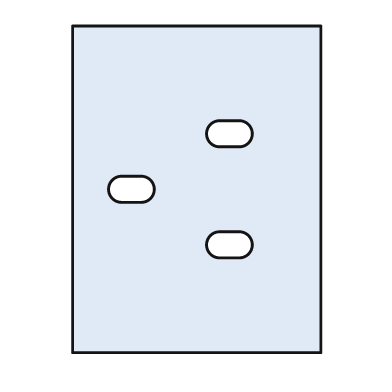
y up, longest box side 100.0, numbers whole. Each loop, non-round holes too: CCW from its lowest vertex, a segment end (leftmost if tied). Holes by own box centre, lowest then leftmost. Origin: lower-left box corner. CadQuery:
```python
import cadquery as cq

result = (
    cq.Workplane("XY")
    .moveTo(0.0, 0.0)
    .lineTo(76.0, 0.0)
    .lineTo(76.0, 100.0)
    .lineTo(0.0, 100.0)
    .close()
    .moveTo(45.0, 29.0)
    .lineTo(51.0, 29.0)
    .threePointArc((55.0, 33.0), (51.0, 37.0))
    .lineTo(45.0, 37.0)
    .threePointArc((41.0, 33.0), (45.0, 29.0))
    .close()
    .moveTo(15.0, 46.0)
    .lineTo(21.0, 46.0)
    .threePointArc((25.0, 50.0), (21.0, 54.0))
    .lineTo(15.0, 54.0)
    .threePointArc((11.0, 50.0), (15.0, 46.0))
    .close()
    .moveTo(45.0, 63.0)
    .lineTo(51.0, 63.0)
    .threePointArc((55.0, 67.0), (51.0, 71.0))
    .lineTo(45.0, 71.0)
    .threePointArc((41.0, 67.0), (45.0, 63.0))
    .close()
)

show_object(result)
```